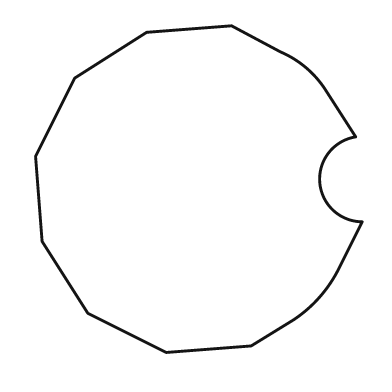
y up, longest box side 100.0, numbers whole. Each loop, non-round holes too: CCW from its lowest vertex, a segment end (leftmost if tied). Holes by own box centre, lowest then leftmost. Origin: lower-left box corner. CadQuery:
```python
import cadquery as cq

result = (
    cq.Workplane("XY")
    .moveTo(40.0, 0.0)
    .lineTo(66.0, 2.0)
    .lineTo(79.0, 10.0)
    .threePointArc((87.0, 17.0), (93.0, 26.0))
    .lineTo(100.0, 40.0)
    .threePointArc((87.0, 52.0), (98.0, 66.0))
    .lineTo(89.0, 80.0)
    .threePointArc((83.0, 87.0), (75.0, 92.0))
    .lineTo(60.0, 100.0)
    .lineTo(34.0, 98.0)
    .lineTo(12.0, 84.0)
    .lineTo(0.0, 60.0)
    .lineTo(2.0, 34.0)
    .lineTo(16.0, 12.0)
    .close()
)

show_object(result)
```